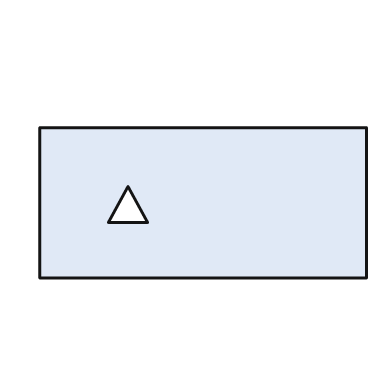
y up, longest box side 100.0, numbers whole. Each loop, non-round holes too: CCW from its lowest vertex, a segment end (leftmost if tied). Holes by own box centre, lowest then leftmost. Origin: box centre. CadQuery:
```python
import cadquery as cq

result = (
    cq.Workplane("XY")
    .moveTo(-50.0, -23.0)
    .lineTo(50.0, -23.0)
    .lineTo(50.0, 23.0)
    .lineTo(-50.0, 23.0)
    .close()
    .moveTo(-29.0, -6.0)
    .lineTo(-17.0, -6.0)
    .lineTo(-23.0, 5.0)
    .close()
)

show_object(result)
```